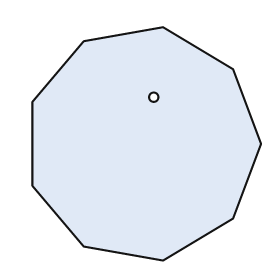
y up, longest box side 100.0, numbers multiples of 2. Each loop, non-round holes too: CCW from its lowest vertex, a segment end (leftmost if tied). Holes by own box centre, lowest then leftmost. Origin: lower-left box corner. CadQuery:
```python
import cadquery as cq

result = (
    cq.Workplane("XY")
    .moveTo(56.0, 0.0)
    .lineTo(86.0, 18.0)
    .lineTo(98.0, 50.0)
    .lineTo(86.0, 82.0)
    .lineTo(56.0, 100.0)
    .lineTo(22.0, 94.0)
    .lineTo(0.0, 68.0)
    .lineTo(0.0, 32.0)
    .lineTo(22.0, 6.0)
    .close()
    .moveTo(52.0, 70.0)
    .circle(2.0)
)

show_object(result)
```